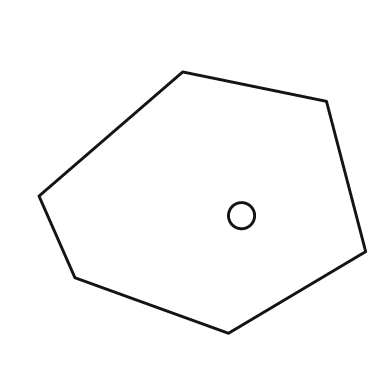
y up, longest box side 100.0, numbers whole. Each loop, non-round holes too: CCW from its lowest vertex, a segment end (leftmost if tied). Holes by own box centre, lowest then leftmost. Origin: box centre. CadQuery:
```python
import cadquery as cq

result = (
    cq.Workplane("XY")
    .moveTo(8.0, -40.0)
    .lineTo(50.0, -15.0)
    .lineTo(38.0, 31.0)
    .lineTo(-6.0, 40.0)
    .lineTo(-50.0, 2.0)
    .lineTo(-39.0, -23.0)
    .close()
    .moveTo(12.0, -4.0)
    .circle(4.0)
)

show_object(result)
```